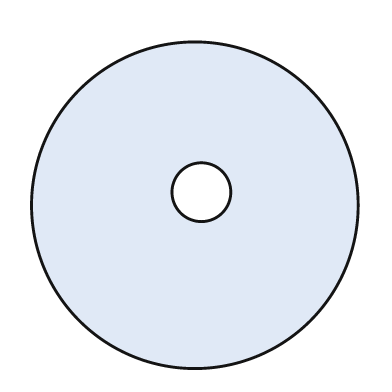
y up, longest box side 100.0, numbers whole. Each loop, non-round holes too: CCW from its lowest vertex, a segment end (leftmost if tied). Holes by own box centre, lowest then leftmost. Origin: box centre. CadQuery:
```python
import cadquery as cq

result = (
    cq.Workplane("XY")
    .moveTo(0.0, 0.0)
    .circle(50.0)
    .moveTo(2.0, 4.0)
    .circle(9.0)
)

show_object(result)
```